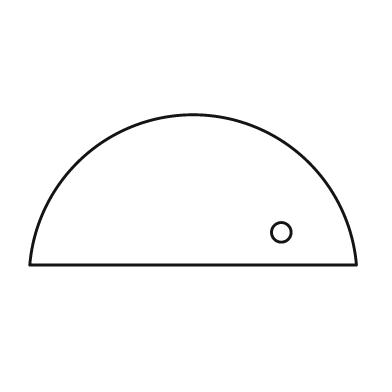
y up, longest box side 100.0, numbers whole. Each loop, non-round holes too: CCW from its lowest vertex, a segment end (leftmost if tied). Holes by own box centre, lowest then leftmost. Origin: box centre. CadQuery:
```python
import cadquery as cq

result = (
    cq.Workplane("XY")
    .moveTo(-50.0, -23.0)
    .lineTo(50.0, -23.0)
    .threePointArc((0.0, 23.0), (-50.0, -23.0))
    .close()
    .moveTo(27.0, -13.0)
    .circle(3.0)
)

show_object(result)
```